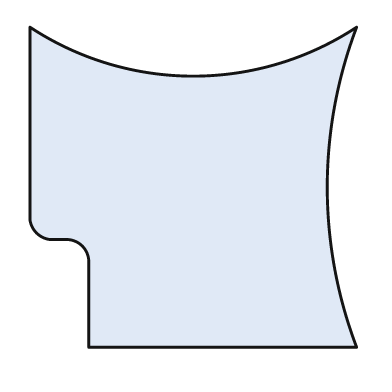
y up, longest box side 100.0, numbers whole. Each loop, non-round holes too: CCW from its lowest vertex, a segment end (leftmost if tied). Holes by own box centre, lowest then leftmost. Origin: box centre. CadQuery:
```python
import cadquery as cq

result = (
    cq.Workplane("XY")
    .moveTo(-32.0, -49.0)
    .lineTo(50.0, -49.0)
    .threePointArc((41.0, 0.0), (50.0, 49.0))
    .threePointArc((0.0, 34.0), (-50.0, 49.0))
    .lineTo(-50.0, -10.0)
    .threePointArc((-48.0, -14.0), (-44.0, -16.0))
    .lineTo(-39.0, -16.0)
    .threePointArc((-34.0, -18.0), (-32.0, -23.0))
    .close()
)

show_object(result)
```